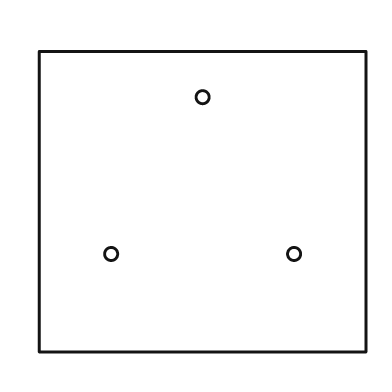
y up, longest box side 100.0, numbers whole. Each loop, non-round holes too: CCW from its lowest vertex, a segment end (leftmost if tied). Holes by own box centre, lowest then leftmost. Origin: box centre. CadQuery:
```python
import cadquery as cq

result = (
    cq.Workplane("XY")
    .moveTo(-50.0, -46.0)
    .lineTo(50.0, -46.0)
    .lineTo(50.0, 46.0)
    .lineTo(-50.0, 46.0)
    .close()
    .moveTo(-28.0, -16.0)
    .circle(2.0)
    .moveTo(28.0, -16.0)
    .circle(2.0)
    .moveTo(0.0, 32.0)
    .circle(2.0)
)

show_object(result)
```